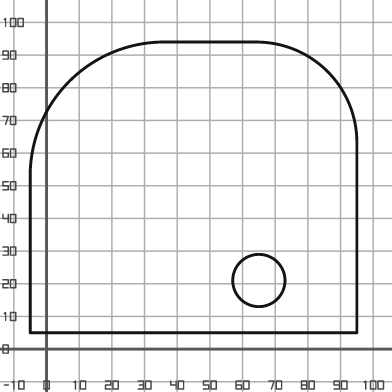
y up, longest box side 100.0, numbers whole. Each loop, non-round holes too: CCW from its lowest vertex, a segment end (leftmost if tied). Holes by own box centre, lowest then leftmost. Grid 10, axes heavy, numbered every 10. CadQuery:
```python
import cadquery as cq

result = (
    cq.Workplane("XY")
    .moveTo(-5.0, 5.0)
    .lineTo(95.0, 5.0)
    .lineTo(95.0, 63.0)
    .threePointArc((86.0, 85.0), (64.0, 94.0))
    .lineTo(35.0, 94.0)
    .threePointArc((7.0, 82.0), (-5.0, 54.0))
    .close()
    .moveTo(65.0, 21.0)
    .circle(8.0)
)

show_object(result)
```